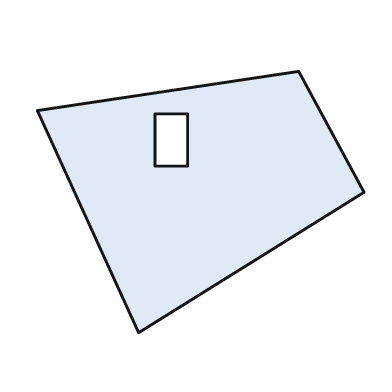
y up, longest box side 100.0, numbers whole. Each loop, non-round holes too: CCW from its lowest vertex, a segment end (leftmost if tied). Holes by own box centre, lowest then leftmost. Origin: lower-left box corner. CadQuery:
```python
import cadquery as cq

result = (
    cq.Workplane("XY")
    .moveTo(31.0, 0.0)
    .lineTo(100.0, 43.0)
    .lineTo(80.0, 80.0)
    .lineTo(0.0, 68.0)
    .close()
    .moveTo(36.0, 51.0)
    .lineTo(46.0, 51.0)
    .lineTo(46.0, 67.0)
    .lineTo(36.0, 67.0)
    .close()
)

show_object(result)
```